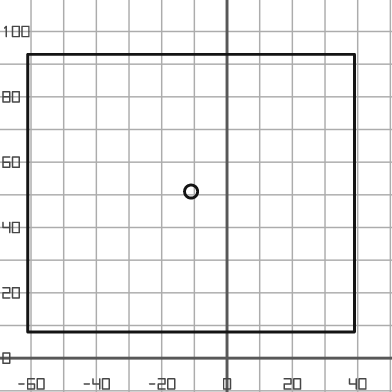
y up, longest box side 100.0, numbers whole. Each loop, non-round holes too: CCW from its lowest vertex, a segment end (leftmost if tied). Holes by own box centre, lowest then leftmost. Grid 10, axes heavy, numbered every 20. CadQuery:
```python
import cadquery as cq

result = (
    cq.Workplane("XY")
    .moveTo(-61.0, 8.0)
    .lineTo(39.0, 8.0)
    .lineTo(39.0, 93.0)
    .lineTo(-61.0, 93.0)
    .close()
    .moveTo(-11.0, 51.0)
    .circle(2.0)
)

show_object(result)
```